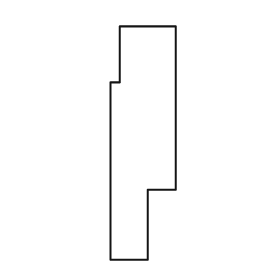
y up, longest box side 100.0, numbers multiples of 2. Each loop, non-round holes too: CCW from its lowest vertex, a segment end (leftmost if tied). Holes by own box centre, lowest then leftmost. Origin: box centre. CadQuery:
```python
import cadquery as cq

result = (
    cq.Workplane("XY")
    .moveTo(-14.0, -50.0)
    .lineTo(2.0, -50.0)
    .lineTo(2.0, -20.0)
    .lineTo(14.0, -20.0)
    .lineTo(14.0, 50.0)
    .lineTo(-10.0, 50.0)
    .lineTo(-10.0, 26.0)
    .lineTo(-14.0, 26.0)
    .close()
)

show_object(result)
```